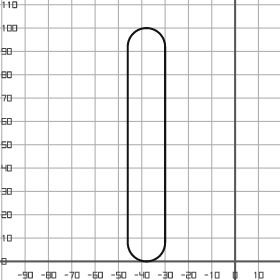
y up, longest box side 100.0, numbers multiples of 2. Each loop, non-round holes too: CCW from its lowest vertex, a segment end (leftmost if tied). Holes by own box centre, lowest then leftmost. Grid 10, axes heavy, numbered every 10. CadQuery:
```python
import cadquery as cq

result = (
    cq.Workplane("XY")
    .moveTo(-46.0, 8.0)
    .threePointArc((-38.0, 0.0), (-30.0, 8.0))
    .lineTo(-30.0, 92.0)
    .threePointArc((-38.0, 100.0), (-46.0, 92.0))
    .close()
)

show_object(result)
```